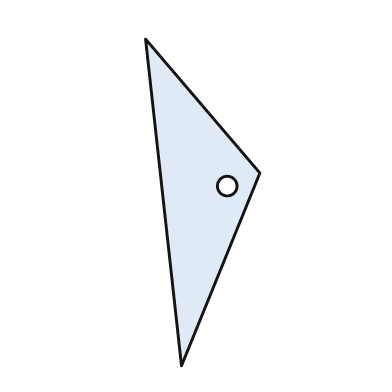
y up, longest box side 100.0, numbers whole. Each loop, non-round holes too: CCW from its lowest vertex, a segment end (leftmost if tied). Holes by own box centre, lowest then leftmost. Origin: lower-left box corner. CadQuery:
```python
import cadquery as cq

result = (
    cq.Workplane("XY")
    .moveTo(11.0, 0.0)
    .lineTo(35.0, 59.0)
    .lineTo(0.0, 100.0)
    .close()
    .moveTo(25.0, 55.0)
    .circle(3.0)
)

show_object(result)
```